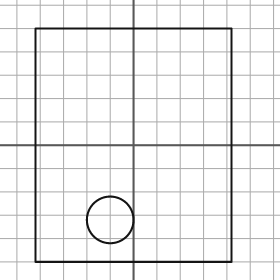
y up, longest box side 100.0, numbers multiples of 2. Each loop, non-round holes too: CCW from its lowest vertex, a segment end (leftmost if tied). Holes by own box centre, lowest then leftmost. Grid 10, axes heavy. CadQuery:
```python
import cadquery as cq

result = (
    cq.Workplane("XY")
    .moveTo(-42.0, -50.0)
    .lineTo(42.0, -50.0)
    .lineTo(42.0, 50.0)
    .lineTo(-42.0, 50.0)
    .close()
    .moveTo(-10.0, -32.0)
    .circle(10.0)
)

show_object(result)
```